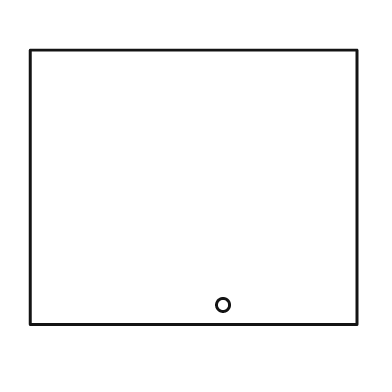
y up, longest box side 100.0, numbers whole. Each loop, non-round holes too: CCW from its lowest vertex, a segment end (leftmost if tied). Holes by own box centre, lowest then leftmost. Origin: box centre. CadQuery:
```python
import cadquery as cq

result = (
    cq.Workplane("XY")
    .moveTo(-50.0, -42.0)
    .lineTo(50.0, -42.0)
    .lineTo(50.0, 42.0)
    .lineTo(-50.0, 42.0)
    .close()
    .moveTo(9.0, -36.0)
    .circle(2.0)
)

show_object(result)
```